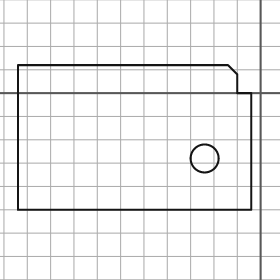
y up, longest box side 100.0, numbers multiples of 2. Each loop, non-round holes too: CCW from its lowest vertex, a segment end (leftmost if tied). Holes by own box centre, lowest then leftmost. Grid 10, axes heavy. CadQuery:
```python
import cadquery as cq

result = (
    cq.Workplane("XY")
    .moveTo(-104.0, -50.0)
    .lineTo(-4.0, -50.0)
    .lineTo(-4.0, 0.0)
    .lineTo(-10.0, 0.0)
    .lineTo(-10.0, 8.0)
    .lineTo(-14.0, 12.0)
    .lineTo(-104.0, 12.0)
    .close()
    .moveTo(-24.0, -28.0)
    .circle(6.0)
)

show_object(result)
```